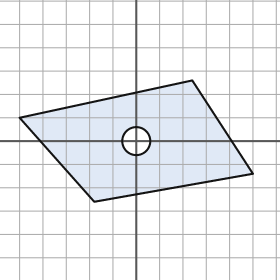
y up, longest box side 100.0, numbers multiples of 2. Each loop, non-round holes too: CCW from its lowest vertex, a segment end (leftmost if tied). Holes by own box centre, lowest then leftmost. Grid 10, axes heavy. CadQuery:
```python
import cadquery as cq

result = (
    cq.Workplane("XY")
    .moveTo(-18.0, -26.0)
    .lineTo(50.0, -14.0)
    .lineTo(24.0, 26.0)
    .lineTo(-50.0, 10.0)
    .close()
    .moveTo(0.0, 0.0)
    .circle(6.0)
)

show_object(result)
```